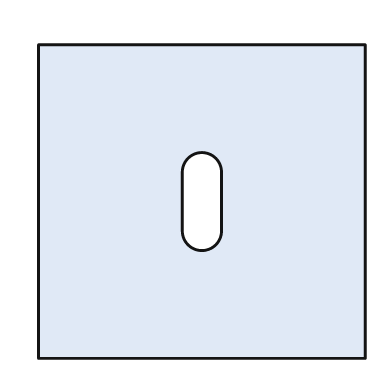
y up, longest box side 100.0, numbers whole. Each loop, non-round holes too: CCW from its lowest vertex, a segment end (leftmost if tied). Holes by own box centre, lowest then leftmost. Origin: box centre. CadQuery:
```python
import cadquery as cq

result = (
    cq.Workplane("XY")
    .moveTo(-50.0, -48.0)
    .lineTo(50.0, -48.0)
    .lineTo(50.0, 48.0)
    .lineTo(-50.0, 48.0)
    .close()
    .moveTo(-6.0, -9.0)
    .threePointArc((0.0, -15.0), (6.0, -9.0))
    .lineTo(6.0, 9.0)
    .threePointArc((0.0, 15.0), (-6.0, 9.0))
    .close()
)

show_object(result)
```